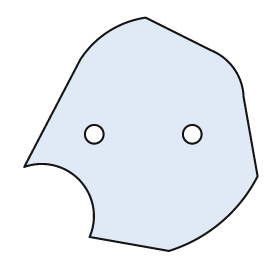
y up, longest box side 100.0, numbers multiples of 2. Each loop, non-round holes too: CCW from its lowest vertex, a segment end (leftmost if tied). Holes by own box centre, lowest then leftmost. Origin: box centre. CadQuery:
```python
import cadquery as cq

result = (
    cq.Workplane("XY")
    .moveTo(12.0, -50.0)
    .threePointArc((34.0, -38.0), (50.0, -18.0))
    .lineTo(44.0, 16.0)
    .threePointArc((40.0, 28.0), (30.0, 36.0))
    .lineTo(2.0, 50.0)
    .threePointArc((-14.0, 44.0), (-26.0, 32.0))
    .lineTo(-50.0, -14.0)
    .threePointArc((-26.0, -20.0), (-22.0, -44.0))
    .close()
    .moveTo(-20.0, 0.0)
    .circle(4.0)
    .moveTo(22.0, 0.0)
    .circle(4.0)
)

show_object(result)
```